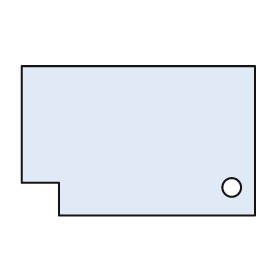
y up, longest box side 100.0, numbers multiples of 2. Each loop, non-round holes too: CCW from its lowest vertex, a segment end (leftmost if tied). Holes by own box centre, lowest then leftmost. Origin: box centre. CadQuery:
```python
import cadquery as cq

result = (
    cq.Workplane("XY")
    .moveTo(-34.0, -32.0)
    .lineTo(50.0, -32.0)
    .lineTo(50.0, 32.0)
    .lineTo(-50.0, 32.0)
    .lineTo(-50.0, -18.0)
    .lineTo(-34.0, -18.0)
    .close()
    .moveTo(40.0, -20.0)
    .circle(4.0)
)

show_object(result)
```